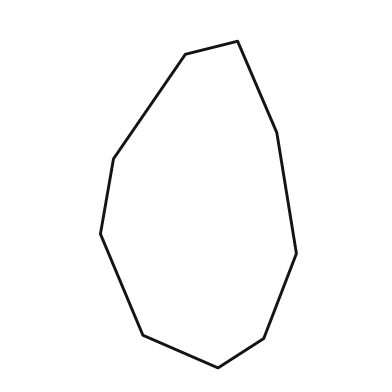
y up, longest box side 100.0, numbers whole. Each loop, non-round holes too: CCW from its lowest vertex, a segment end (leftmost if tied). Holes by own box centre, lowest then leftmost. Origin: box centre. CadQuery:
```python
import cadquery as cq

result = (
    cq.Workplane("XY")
    .moveTo(6.0, -50.0)
    .lineTo(20.0, -41.0)
    .lineTo(30.0, -15.0)
    .lineTo(24.0, 22.0)
    .lineTo(12.0, 50.0)
    .lineTo(-4.0, 46.0)
    .lineTo(-26.0, 14.0)
    .lineTo(-30.0, -9.0)
    .lineTo(-17.0, -40.0)
    .close()
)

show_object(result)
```